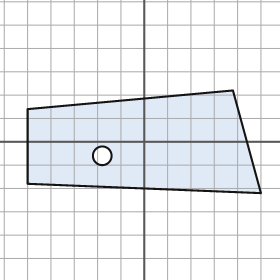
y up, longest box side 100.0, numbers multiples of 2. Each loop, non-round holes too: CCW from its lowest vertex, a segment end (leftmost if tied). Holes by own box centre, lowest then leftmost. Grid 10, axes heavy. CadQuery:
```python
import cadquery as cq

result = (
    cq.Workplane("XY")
    .moveTo(50.0, -22.0)
    .lineTo(38.0, 22.0)
    .lineTo(-50.0, 14.0)
    .lineTo(-50.0, -18.0)
    .close()
    .moveTo(-18.0, -6.0)
    .circle(4.0)
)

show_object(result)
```